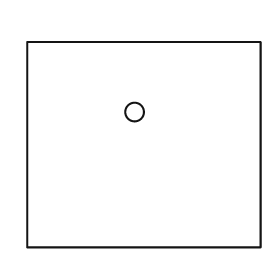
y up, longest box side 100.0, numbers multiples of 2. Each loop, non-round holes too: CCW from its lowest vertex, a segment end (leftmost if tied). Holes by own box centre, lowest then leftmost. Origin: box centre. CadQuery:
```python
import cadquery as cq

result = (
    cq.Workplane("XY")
    .moveTo(-50.0, -44.0)
    .lineTo(50.0, -44.0)
    .lineTo(50.0, 44.0)
    .lineTo(-50.0, 44.0)
    .close()
    .moveTo(-4.0, 14.0)
    .circle(4.0)
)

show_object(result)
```